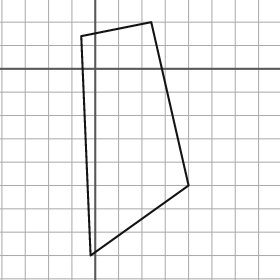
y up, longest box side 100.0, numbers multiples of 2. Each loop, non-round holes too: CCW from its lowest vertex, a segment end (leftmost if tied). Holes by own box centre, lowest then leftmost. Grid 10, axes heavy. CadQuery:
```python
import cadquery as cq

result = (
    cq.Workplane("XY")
    .moveTo(-2.0, -80.0)
    .lineTo(40.0, -50.0)
    .lineTo(24.0, 20.0)
    .lineTo(-6.0, 14.0)
    .close()
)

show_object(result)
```